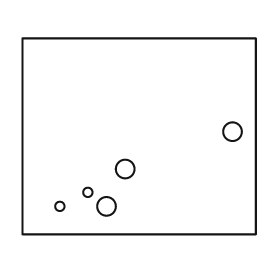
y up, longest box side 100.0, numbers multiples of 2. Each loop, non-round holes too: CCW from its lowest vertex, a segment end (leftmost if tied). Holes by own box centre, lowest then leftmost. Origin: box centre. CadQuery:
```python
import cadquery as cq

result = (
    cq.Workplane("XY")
    .moveTo(-50.0, -42.0)
    .lineTo(50.0, -42.0)
    .lineTo(50.0, 42.0)
    .lineTo(-50.0, 42.0)
    .close()
    .moveTo(-34.0, -30.0)
    .circle(2.0)
    .moveTo(-14.0, -30.0)
    .circle(4.0)
    .moveTo(-22.0, -24.0)
    .circle(2.0)
    .moveTo(-6.0, -14.0)
    .circle(4.0)
    .moveTo(40.0, 2.0)
    .circle(4.0)
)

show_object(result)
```